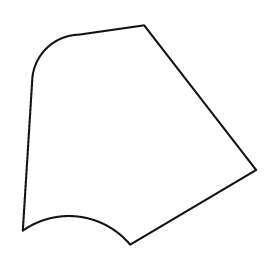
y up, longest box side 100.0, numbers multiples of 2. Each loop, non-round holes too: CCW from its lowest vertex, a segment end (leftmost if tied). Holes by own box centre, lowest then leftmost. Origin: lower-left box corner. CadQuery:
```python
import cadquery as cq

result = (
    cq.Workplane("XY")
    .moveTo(46.0, 0.0)
    .lineTo(100.0, 32.0)
    .lineTo(52.0, 94.0)
    .lineTo(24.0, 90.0)
    .threePointArc((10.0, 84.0), (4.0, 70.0))
    .lineTo(0.0, 6.0)
    .threePointArc((24.0, 12.0), (46.0, 0.0))
    .close()
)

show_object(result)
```